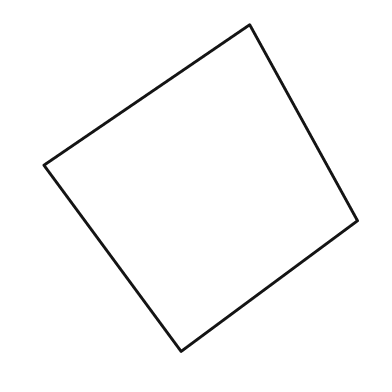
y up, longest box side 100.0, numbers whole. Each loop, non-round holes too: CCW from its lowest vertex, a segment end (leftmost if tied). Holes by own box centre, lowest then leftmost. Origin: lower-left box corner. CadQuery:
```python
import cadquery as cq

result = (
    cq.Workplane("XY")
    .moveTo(42.0, 0.0)
    .lineTo(96.0, 40.0)
    .lineTo(63.0, 100.0)
    .lineTo(0.0, 57.0)
    .close()
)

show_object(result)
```